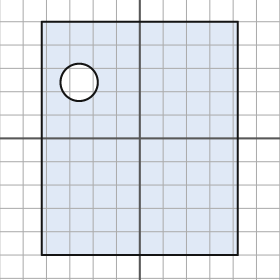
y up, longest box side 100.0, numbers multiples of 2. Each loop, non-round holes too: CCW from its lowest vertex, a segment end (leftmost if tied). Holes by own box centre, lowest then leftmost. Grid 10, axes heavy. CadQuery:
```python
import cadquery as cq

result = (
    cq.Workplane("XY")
    .moveTo(-42.0, -50.0)
    .lineTo(42.0, -50.0)
    .lineTo(42.0, 50.0)
    .lineTo(-42.0, 50.0)
    .close()
    .moveTo(-26.0, 24.0)
    .circle(8.0)
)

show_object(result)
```